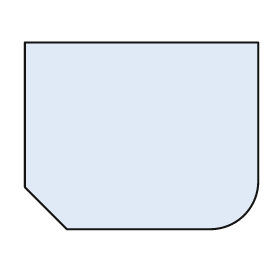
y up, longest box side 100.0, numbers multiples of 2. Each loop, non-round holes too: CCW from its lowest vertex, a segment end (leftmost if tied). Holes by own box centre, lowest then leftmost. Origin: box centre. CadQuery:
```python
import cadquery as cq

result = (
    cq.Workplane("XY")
    .moveTo(-32.0, -40.0)
    .lineTo(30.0, -40.0)
    .threePointArc((44.0, -34.0), (50.0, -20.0))
    .lineTo(50.0, 40.0)
    .lineTo(-50.0, 40.0)
    .lineTo(-50.0, -22.0)
    .close()
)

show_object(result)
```